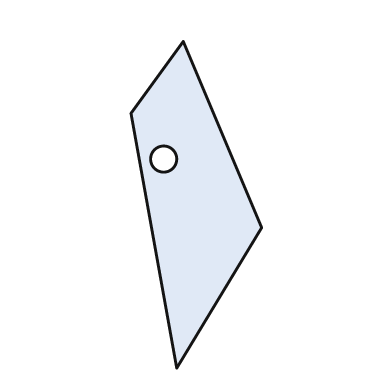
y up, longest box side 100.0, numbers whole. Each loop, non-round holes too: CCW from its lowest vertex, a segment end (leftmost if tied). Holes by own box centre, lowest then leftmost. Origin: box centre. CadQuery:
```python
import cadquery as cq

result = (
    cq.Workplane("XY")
    .moveTo(-6.0, -50.0)
    .lineTo(20.0, -7.0)
    .lineTo(-4.0, 50.0)
    .lineTo(-20.0, 28.0)
    .close()
    .moveTo(-10.0, 14.0)
    .circle(4.0)
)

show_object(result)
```